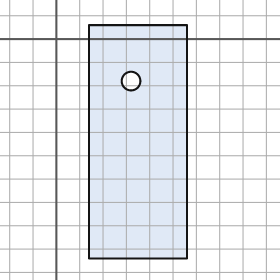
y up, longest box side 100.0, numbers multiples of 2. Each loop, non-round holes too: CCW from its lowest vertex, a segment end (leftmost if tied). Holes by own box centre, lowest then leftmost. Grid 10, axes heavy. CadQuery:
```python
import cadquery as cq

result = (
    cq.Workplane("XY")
    .moveTo(14.0, -94.0)
    .lineTo(56.0, -94.0)
    .lineTo(56.0, 6.0)
    .lineTo(14.0, 6.0)
    .close()
    .moveTo(32.0, -18.0)
    .circle(4.0)
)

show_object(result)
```